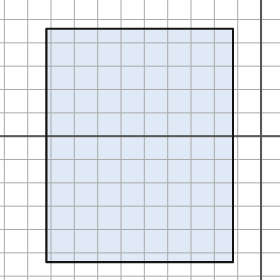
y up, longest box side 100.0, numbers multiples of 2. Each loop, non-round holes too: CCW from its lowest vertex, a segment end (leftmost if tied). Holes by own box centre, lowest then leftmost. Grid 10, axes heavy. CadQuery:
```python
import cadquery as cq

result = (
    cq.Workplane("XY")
    .moveTo(-92.0, -54.0)
    .lineTo(-12.0, -54.0)
    .lineTo(-12.0, 46.0)
    .lineTo(-92.0, 46.0)
    .close()
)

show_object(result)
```